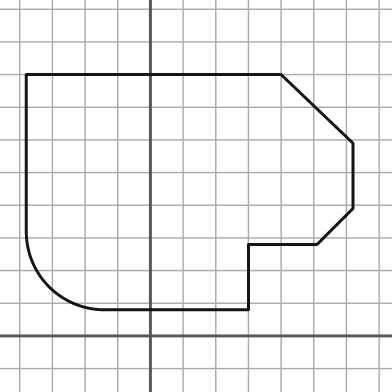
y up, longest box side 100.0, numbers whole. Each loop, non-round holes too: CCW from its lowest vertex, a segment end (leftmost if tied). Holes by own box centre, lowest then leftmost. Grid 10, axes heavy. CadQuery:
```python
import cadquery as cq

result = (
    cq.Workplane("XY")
    .moveTo(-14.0, 8.0)
    .lineTo(30.0, 8.0)
    .lineTo(30.0, 28.0)
    .lineTo(51.0, 28.0)
    .lineTo(62.0, 39.0)
    .lineTo(62.0, 59.0)
    .lineTo(40.0, 80.0)
    .lineTo(-38.0, 80.0)
    .lineTo(-38.0, 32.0)
    .threePointArc((-31.0, 15.0), (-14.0, 8.0))
    .close()
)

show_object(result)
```